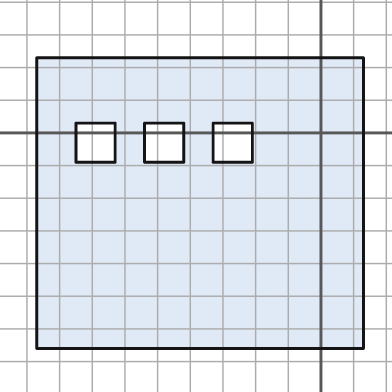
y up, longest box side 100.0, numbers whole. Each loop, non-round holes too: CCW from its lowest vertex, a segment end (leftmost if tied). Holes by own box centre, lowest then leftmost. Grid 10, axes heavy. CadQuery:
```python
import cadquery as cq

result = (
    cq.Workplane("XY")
    .moveTo(-87.0, -66.0)
    .lineTo(13.0, -66.0)
    .lineTo(13.0, 23.0)
    .lineTo(-87.0, 23.0)
    .close()
    .moveTo(-75.0, -9.0)
    .lineTo(-63.0, -9.0)
    .lineTo(-63.0, 3.0)
    .lineTo(-75.0, 3.0)
    .close()
    .moveTo(-54.0, -9.0)
    .lineTo(-42.0, -9.0)
    .lineTo(-42.0, 3.0)
    .lineTo(-54.0, 3.0)
    .close()
    .moveTo(-33.0, -9.0)
    .lineTo(-21.0, -9.0)
    .lineTo(-21.0, 3.0)
    .lineTo(-33.0, 3.0)
    .close()
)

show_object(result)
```